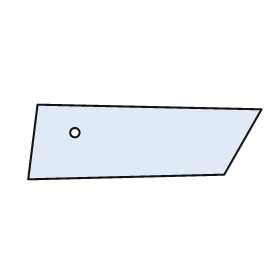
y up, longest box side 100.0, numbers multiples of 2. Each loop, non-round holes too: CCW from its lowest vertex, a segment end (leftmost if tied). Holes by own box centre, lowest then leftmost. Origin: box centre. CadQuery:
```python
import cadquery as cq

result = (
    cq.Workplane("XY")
    .moveTo(-50.0, -16.0)
    .lineTo(34.0, -14.0)
    .lineTo(50.0, 14.0)
    .lineTo(-46.0, 16.0)
    .close()
    .moveTo(-30.0, 4.0)
    .circle(2.0)
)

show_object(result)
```